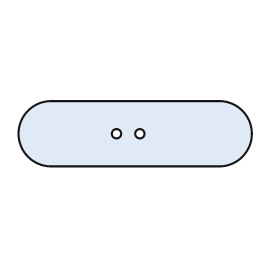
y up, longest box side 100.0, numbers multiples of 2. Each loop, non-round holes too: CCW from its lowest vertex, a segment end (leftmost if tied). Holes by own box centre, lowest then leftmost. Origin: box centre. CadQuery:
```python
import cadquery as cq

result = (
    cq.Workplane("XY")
    .moveTo(-36.0, -14.0)
    .lineTo(36.0, -14.0)
    .threePointArc((50.0, 0.0), (36.0, 14.0))
    .lineTo(-36.0, 14.0)
    .threePointArc((-50.0, 0.0), (-36.0, -14.0))
    .close()
    .moveTo(-8.0, 0.0)
    .circle(2.0)
    .moveTo(2.0, 0.0)
    .circle(2.0)
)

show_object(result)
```